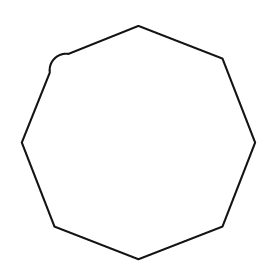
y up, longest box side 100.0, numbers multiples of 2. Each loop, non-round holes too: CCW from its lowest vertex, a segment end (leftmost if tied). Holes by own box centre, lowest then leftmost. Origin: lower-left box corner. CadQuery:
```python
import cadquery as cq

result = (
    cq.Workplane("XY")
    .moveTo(50.0, 0.0)
    .lineTo(86.0, 14.0)
    .lineTo(100.0, 50.0)
    .lineTo(86.0, 86.0)
    .lineTo(50.0, 100.0)
    .lineTo(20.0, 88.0)
    .threePointArc((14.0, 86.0), (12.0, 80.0))
    .lineTo(0.0, 50.0)
    .lineTo(14.0, 14.0)
    .close()
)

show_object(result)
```